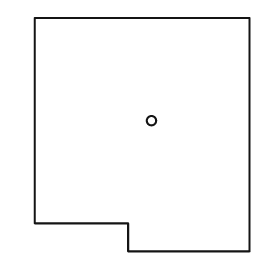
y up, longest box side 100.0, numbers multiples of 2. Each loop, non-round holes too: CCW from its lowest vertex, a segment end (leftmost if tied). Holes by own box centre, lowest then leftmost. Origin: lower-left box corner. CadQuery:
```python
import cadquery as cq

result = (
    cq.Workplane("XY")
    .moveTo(40.0, 0.0)
    .lineTo(92.0, 0.0)
    .lineTo(92.0, 100.0)
    .lineTo(0.0, 100.0)
    .lineTo(0.0, 12.0)
    .lineTo(40.0, 12.0)
    .close()
    .moveTo(50.0, 56.0)
    .circle(2.0)
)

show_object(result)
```